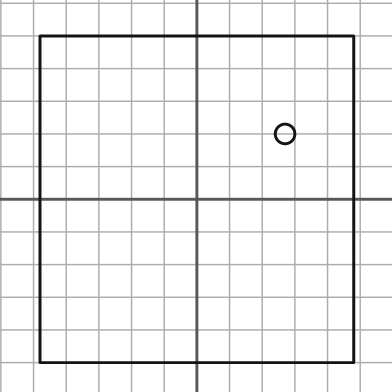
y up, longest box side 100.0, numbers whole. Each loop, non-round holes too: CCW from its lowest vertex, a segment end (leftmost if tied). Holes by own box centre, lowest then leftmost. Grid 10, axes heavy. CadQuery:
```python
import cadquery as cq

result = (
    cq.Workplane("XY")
    .moveTo(-48.0, -50.0)
    .lineTo(48.0, -50.0)
    .lineTo(48.0, 50.0)
    .lineTo(-48.0, 50.0)
    .close()
    .moveTo(27.0, 20.0)
    .circle(3.0)
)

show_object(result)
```